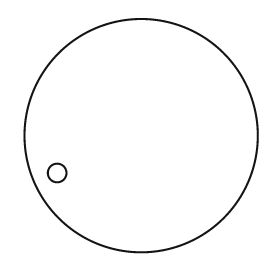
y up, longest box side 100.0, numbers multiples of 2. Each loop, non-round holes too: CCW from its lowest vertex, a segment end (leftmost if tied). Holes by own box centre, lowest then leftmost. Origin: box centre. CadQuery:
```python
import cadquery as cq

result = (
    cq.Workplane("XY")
    .moveTo(0.0, 0.0)
    .circle(50.0)
    .moveTo(-36.0, -16.0)
    .circle(4.0)
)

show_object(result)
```